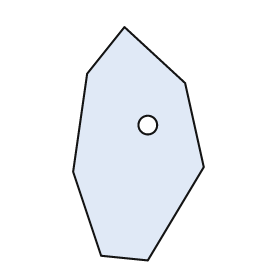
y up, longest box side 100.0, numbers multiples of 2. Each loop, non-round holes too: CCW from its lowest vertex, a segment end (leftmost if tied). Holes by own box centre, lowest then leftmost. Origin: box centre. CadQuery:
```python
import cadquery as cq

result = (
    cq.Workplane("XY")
    .moveTo(4.0, -50.0)
    .lineTo(28.0, -10.0)
    .lineTo(20.0, 26.0)
    .lineTo(-6.0, 50.0)
    .lineTo(-22.0, 30.0)
    .lineTo(-28.0, -12.0)
    .lineTo(-16.0, -48.0)
    .close()
    .moveTo(4.0, 8.0)
    .circle(4.0)
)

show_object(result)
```